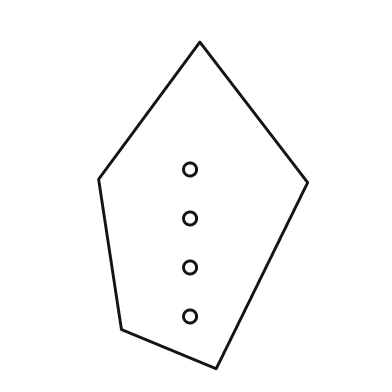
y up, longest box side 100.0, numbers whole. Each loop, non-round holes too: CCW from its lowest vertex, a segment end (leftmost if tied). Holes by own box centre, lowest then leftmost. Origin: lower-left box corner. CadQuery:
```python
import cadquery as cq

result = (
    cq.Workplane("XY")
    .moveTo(36.0, 0.0)
    .lineTo(64.0, 57.0)
    .lineTo(31.0, 100.0)
    .lineTo(0.0, 58.0)
    .lineTo(7.0, 12.0)
    .close()
    .moveTo(28.0, 16.0)
    .circle(2.0)
    .moveTo(28.0, 31.0)
    .circle(2.0)
    .moveTo(28.0, 46.0)
    .circle(2.0)
    .moveTo(28.0, 61.0)
    .circle(2.0)
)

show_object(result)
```